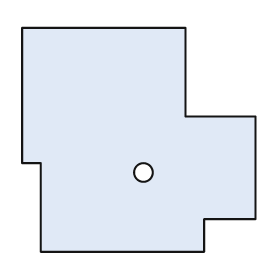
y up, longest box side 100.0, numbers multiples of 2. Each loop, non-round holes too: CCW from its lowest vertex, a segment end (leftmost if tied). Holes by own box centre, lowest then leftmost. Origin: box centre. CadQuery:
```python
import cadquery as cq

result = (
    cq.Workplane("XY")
    .moveTo(-42.0, -48.0)
    .lineTo(28.0, -48.0)
    .lineTo(28.0, -34.0)
    .lineTo(50.0, -34.0)
    .lineTo(50.0, 10.0)
    .lineTo(20.0, 10.0)
    .lineTo(20.0, 48.0)
    .lineTo(-50.0, 48.0)
    .lineTo(-50.0, -10.0)
    .lineTo(-42.0, -10.0)
    .close()
    .moveTo(2.0, -14.0)
    .circle(4.0)
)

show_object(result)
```